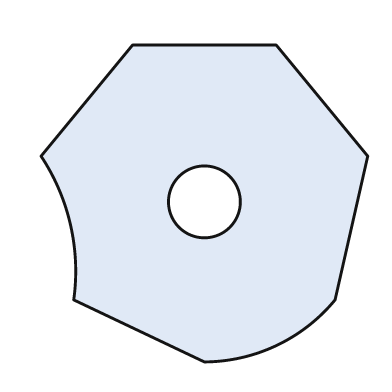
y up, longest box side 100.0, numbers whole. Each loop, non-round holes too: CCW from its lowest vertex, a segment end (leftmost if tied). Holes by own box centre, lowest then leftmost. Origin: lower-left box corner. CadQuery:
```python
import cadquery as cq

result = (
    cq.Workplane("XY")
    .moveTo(50.0, 0.0)
    .threePointArc((72.0, 5.0), (90.0, 19.0))
    .lineTo(100.0, 63.0)
    .lineTo(72.0, 97.0)
    .lineTo(28.0, 97.0)
    .lineTo(0.0, 63.0)
    .threePointArc((9.0, 42.0), (10.0, 19.0))
    .close()
    .moveTo(50.0, 49.0)
    .circle(11.0)
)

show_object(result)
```